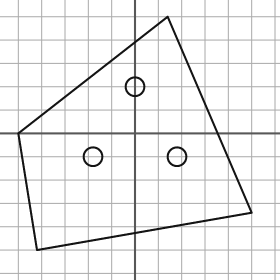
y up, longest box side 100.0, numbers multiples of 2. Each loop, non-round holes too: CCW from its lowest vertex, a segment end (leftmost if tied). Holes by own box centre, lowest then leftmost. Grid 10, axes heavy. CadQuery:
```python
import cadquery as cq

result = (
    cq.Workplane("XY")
    .moveTo(-42.0, -50.0)
    .lineTo(50.0, -34.0)
    .lineTo(14.0, 50.0)
    .lineTo(-50.0, 0.0)
    .close()
    .moveTo(-18.0, -10.0)
    .circle(4.0)
    .moveTo(18.0, -10.0)
    .circle(4.0)
    .moveTo(0.0, 20.0)
    .circle(4.0)
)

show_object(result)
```